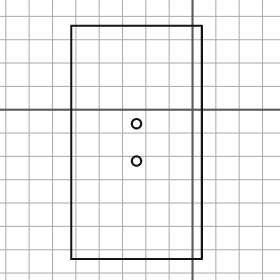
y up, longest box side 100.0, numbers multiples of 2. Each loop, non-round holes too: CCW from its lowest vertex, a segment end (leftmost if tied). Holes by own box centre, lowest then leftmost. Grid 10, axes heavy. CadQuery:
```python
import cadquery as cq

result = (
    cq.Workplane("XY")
    .moveTo(-52.0, -64.0)
    .lineTo(4.0, -64.0)
    .lineTo(4.0, 36.0)
    .lineTo(-52.0, 36.0)
    .close()
    .moveTo(-24.0, -22.0)
    .circle(2.0)
    .moveTo(-24.0, -6.0)
    .circle(2.0)
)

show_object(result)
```